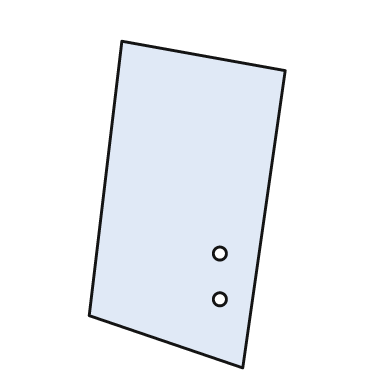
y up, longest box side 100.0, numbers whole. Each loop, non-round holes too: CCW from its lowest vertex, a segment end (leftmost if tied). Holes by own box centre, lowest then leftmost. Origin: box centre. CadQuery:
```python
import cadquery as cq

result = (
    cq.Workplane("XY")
    .moveTo(17.0, -50.0)
    .lineTo(30.0, 41.0)
    .lineTo(-20.0, 50.0)
    .lineTo(-30.0, -34.0)
    .close()
    .moveTo(10.0, -29.0)
    .circle(2.0)
    .moveTo(10.0, -15.0)
    .circle(2.0)
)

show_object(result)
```